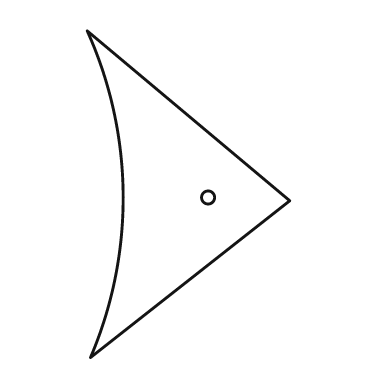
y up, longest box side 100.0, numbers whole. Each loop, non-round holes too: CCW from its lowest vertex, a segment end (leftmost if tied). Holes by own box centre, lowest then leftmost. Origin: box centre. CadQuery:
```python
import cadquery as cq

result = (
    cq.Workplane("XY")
    .moveTo(-30.0, -50.0)
    .lineTo(31.0, -2.0)
    .lineTo(-31.0, 50.0)
    .threePointArc((-20.0, 0.0), (-30.0, -50.0))
    .close()
    .moveTo(6.0, -1.0)
    .circle(2.0)
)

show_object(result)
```